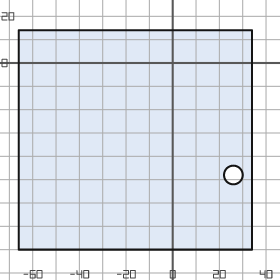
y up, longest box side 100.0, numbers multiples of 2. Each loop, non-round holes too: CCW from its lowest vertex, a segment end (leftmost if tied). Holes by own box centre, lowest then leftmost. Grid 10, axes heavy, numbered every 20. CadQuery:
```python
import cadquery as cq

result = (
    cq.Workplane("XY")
    .moveTo(-66.0, -80.0)
    .lineTo(34.0, -80.0)
    .lineTo(34.0, 14.0)
    .lineTo(-66.0, 14.0)
    .close()
    .moveTo(26.0, -48.0)
    .circle(4.0)
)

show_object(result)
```